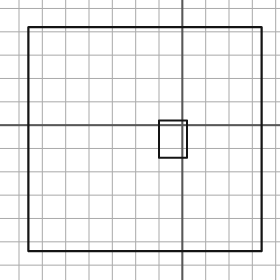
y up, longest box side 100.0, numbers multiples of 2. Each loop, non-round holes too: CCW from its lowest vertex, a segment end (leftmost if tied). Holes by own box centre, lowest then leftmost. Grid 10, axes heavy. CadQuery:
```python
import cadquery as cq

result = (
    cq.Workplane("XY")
    .moveTo(-66.0, -54.0)
    .lineTo(34.0, -54.0)
    .lineTo(34.0, 42.0)
    .lineTo(-66.0, 42.0)
    .close()
    .moveTo(-10.0, -14.0)
    .lineTo(2.0, -14.0)
    .lineTo(2.0, 2.0)
    .lineTo(-10.0, 2.0)
    .close()
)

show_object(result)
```